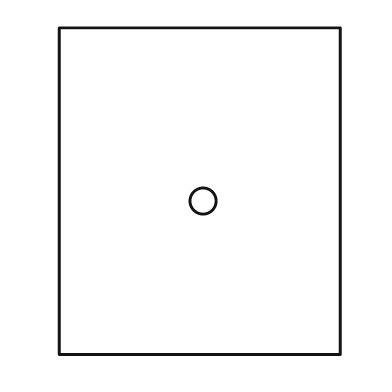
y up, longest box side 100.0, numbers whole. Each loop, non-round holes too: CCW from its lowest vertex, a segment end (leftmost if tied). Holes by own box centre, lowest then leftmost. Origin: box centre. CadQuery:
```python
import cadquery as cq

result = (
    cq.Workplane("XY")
    .moveTo(-43.0, -50.0)
    .lineTo(43.0, -50.0)
    .lineTo(43.0, 50.0)
    .lineTo(-43.0, 50.0)
    .close()
    .moveTo(1.0, -3.0)
    .circle(4.0)
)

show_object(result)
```